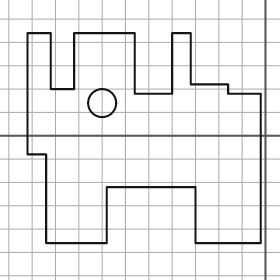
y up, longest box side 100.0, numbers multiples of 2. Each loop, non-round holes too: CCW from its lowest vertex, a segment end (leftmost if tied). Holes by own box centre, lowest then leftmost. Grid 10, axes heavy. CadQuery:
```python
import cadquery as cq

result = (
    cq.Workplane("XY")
    .moveTo(-94.0, -46.0)
    .lineTo(-68.0, -46.0)
    .lineTo(-68.0, -22.0)
    .lineTo(-30.0, -22.0)
    .lineTo(-30.0, -46.0)
    .lineTo(-2.0, -46.0)
    .lineTo(-2.0, 18.0)
    .lineTo(-16.0, 18.0)
    .lineTo(-16.0, 22.0)
    .lineTo(-32.0, 22.0)
    .lineTo(-32.0, 44.0)
    .lineTo(-40.0, 44.0)
    .lineTo(-40.0, 18.0)
    .lineTo(-56.0, 18.0)
    .lineTo(-56.0, 44.0)
    .lineTo(-82.0, 44.0)
    .lineTo(-82.0, 20.0)
    .lineTo(-92.0, 20.0)
    .lineTo(-92.0, 44.0)
    .lineTo(-102.0, 44.0)
    .lineTo(-102.0, -8.0)
    .lineTo(-94.0, -8.0)
    .close()
    .moveTo(-70.0, 14.0)
    .circle(6.0)
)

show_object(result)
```